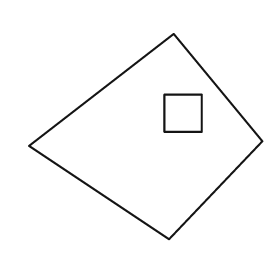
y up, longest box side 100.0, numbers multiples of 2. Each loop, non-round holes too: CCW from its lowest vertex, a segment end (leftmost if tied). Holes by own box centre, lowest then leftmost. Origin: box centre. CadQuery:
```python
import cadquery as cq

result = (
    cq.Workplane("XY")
    .moveTo(10.0, -44.0)
    .lineTo(50.0, -2.0)
    .lineTo(12.0, 44.0)
    .lineTo(-50.0, -4.0)
    .close()
    .moveTo(8.0, 2.0)
    .lineTo(24.0, 2.0)
    .lineTo(24.0, 18.0)
    .lineTo(8.0, 18.0)
    .close()
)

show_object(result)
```